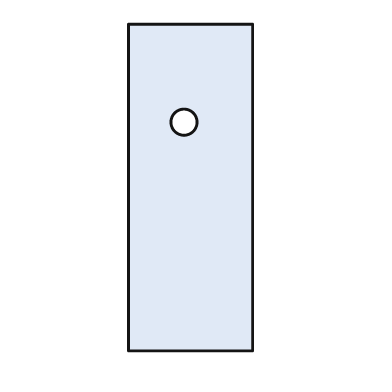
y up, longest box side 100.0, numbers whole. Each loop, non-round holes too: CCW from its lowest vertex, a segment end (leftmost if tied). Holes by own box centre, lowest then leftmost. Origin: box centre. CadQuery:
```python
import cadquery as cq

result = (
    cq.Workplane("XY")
    .moveTo(-19.0, -50.0)
    .lineTo(19.0, -50.0)
    .lineTo(19.0, 50.0)
    .lineTo(-19.0, 50.0)
    .close()
    .moveTo(-2.0, 20.0)
    .circle(4.0)
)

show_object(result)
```